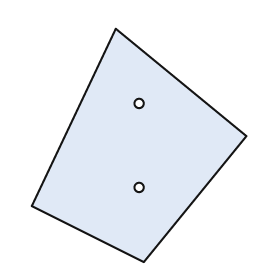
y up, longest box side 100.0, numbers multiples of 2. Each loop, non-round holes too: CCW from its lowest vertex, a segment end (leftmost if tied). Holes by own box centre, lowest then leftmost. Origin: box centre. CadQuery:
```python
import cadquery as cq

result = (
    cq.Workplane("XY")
    .moveTo(2.0, -50.0)
    .lineTo(46.0, 4.0)
    .lineTo(-10.0, 50.0)
    .lineTo(-46.0, -26.0)
    .close()
    .moveTo(0.0, -18.0)
    .circle(2.0)
    .moveTo(0.0, 18.0)
    .circle(2.0)
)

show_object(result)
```